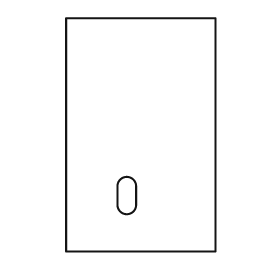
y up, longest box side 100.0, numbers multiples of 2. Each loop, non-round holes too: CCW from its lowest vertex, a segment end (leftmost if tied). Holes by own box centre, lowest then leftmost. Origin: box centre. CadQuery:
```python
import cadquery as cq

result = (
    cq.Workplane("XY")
    .moveTo(-32.0, -50.0)
    .lineTo(32.0, -50.0)
    .lineTo(32.0, 50.0)
    .lineTo(-32.0, 50.0)
    .close()
    .moveTo(-10.0, -30.0)
    .threePointArc((-6.0, -34.0), (-2.0, -30.0))
    .lineTo(-2.0, -22.0)
    .threePointArc((-6.0, -18.0), (-10.0, -22.0))
    .close()
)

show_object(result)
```